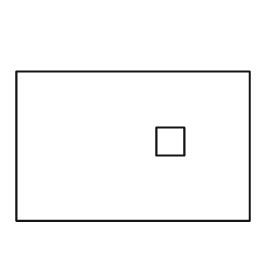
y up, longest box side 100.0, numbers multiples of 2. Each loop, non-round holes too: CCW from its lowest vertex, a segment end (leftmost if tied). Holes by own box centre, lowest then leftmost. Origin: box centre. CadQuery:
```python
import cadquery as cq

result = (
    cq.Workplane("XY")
    .moveTo(-50.0, -32.0)
    .lineTo(50.0, -32.0)
    .lineTo(50.0, 32.0)
    .lineTo(-50.0, 32.0)
    .close()
    .moveTo(10.0, -4.0)
    .lineTo(22.0, -4.0)
    .lineTo(22.0, 8.0)
    .lineTo(10.0, 8.0)
    .close()
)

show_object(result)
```